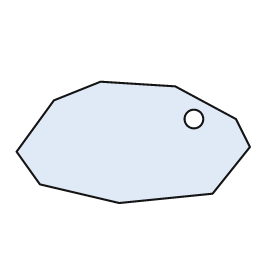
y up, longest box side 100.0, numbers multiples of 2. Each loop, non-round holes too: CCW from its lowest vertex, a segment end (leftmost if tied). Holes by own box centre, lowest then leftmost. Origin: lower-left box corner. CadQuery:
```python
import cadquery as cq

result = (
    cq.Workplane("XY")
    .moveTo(44.0, 0.0)
    .lineTo(84.0, 4.0)
    .lineTo(100.0, 24.0)
    .lineTo(94.0, 36.0)
    .lineTo(68.0, 50.0)
    .lineTo(36.0, 52.0)
    .lineTo(16.0, 44.0)
    .lineTo(0.0, 22.0)
    .lineTo(10.0, 8.0)
    .close()
    .moveTo(76.0, 36.0)
    .circle(4.0)
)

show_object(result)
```